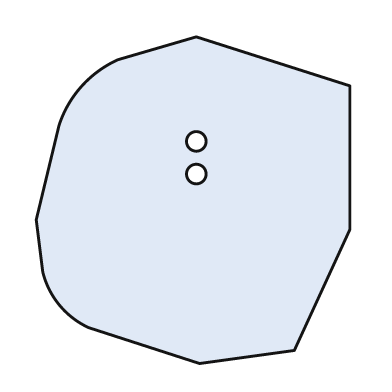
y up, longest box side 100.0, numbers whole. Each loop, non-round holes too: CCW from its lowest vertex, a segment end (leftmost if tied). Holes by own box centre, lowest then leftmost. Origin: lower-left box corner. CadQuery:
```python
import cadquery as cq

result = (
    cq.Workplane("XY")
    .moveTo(50.0, 0.0)
    .lineTo(79.0, 4.0)
    .lineTo(96.0, 41.0)
    .lineTo(96.0, 85.0)
    .lineTo(49.0, 100.0)
    .lineTo(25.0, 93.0)
    .threePointArc((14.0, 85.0), (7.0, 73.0))
    .lineTo(0.0, 44.0)
    .lineTo(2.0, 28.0)
    .threePointArc((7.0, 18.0), (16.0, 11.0))
    .close()
    .moveTo(49.0, 58.0)
    .circle(3.0)
    .moveTo(49.0, 68.0)
    .circle(3.0)
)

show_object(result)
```